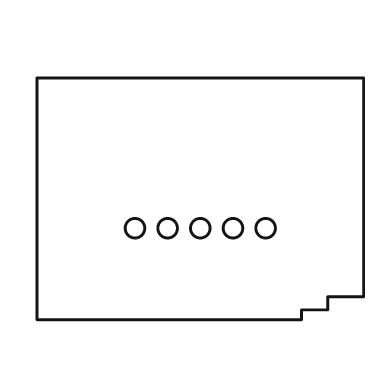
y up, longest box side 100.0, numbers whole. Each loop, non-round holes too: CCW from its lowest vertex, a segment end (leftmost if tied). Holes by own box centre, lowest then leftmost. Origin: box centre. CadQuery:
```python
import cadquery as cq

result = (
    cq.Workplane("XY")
    .moveTo(-50.0, -37.0)
    .lineTo(31.0, -37.0)
    .lineTo(31.0, -34.0)
    .lineTo(39.0, -34.0)
    .lineTo(39.0, -30.0)
    .lineTo(50.0, -30.0)
    .lineTo(50.0, 37.0)
    .lineTo(-50.0, 37.0)
    .close()
    .moveTo(-20.0, -9.0)
    .circle(3.0)
    .moveTo(-10.0, -9.0)
    .circle(3.0)
    .moveTo(0.0, -9.0)
    .circle(3.0)
    .moveTo(10.0, -9.0)
    .circle(3.0)
    .moveTo(20.0, -9.0)
    .circle(3.0)
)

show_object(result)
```